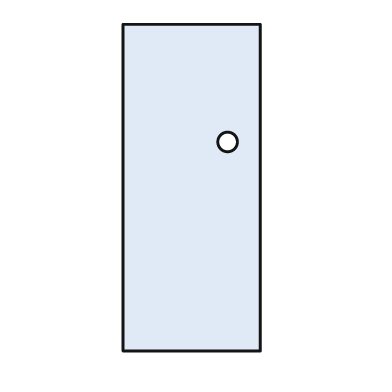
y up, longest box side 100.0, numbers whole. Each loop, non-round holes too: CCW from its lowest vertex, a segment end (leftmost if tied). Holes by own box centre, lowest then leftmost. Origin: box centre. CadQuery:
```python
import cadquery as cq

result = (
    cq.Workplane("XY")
    .moveTo(-21.0, -50.0)
    .lineTo(21.0, -50.0)
    .lineTo(21.0, 50.0)
    .lineTo(-21.0, 50.0)
    .close()
    .moveTo(11.0, 14.0)
    .circle(3.0)
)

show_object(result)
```